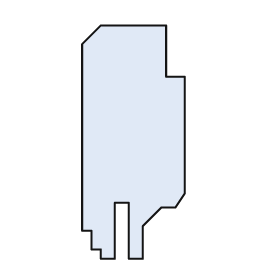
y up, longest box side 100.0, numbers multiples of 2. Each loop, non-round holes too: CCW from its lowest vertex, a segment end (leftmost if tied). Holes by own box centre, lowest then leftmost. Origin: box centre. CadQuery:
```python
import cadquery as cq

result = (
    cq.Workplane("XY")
    .moveTo(-14.0, -50.0)
    .lineTo(-8.0, -50.0)
    .lineTo(-8.0, -26.0)
    .lineTo(-2.0, -26.0)
    .lineTo(-2.0, -50.0)
    .lineTo(4.0, -50.0)
    .lineTo(4.0, -36.0)
    .lineTo(12.0, -28.0)
    .lineTo(18.0, -28.0)
    .lineTo(22.0, -22.0)
    .lineTo(22.0, 28.0)
    .lineTo(14.0, 28.0)
    .lineTo(14.0, 50.0)
    .lineTo(-14.0, 50.0)
    .lineTo(-22.0, 42.0)
    .lineTo(-22.0, -38.0)
    .lineTo(-18.0, -38.0)
    .lineTo(-18.0, -46.0)
    .lineTo(-14.0, -46.0)
    .close()
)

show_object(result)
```